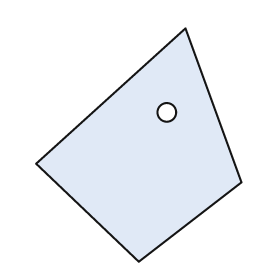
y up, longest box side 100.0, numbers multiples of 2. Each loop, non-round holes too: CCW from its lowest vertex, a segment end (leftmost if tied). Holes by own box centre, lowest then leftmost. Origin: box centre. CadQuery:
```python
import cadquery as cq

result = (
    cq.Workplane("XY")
    .moveTo(0.0, -50.0)
    .lineTo(44.0, -16.0)
    .lineTo(20.0, 50.0)
    .lineTo(-44.0, -8.0)
    .close()
    .moveTo(12.0, 14.0)
    .circle(4.0)
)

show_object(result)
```